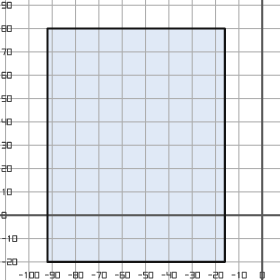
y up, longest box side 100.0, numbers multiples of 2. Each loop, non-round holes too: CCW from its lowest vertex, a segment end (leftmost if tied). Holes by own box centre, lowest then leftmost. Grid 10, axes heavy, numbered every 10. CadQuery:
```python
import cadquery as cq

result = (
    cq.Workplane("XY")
    .moveTo(-92.0, -20.0)
    .lineTo(-16.0, -20.0)
    .lineTo(-16.0, 80.0)
    .lineTo(-92.0, 80.0)
    .close()
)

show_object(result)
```